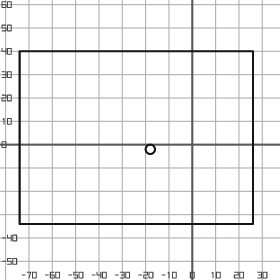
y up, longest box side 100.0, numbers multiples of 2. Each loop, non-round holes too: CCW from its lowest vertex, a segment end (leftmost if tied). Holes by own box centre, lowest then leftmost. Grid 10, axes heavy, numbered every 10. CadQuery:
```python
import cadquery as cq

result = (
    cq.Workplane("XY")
    .moveTo(-74.0, -34.0)
    .lineTo(26.0, -34.0)
    .lineTo(26.0, 40.0)
    .lineTo(-74.0, 40.0)
    .close()
    .moveTo(-18.0, -2.0)
    .circle(2.0)
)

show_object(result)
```